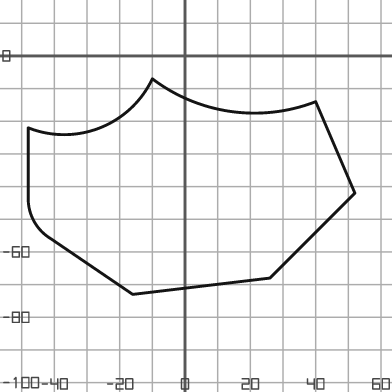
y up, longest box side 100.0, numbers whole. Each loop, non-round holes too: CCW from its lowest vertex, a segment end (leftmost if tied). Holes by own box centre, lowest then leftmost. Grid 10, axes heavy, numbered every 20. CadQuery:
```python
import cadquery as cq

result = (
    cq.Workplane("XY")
    .moveTo(-16.0, -73.0)
    .lineTo(26.0, -68.0)
    .lineTo(52.0, -42.0)
    .lineTo(40.0, -14.0)
    .threePointArc((14.0, -17.0), (-10.0, -7.0))
    .threePointArc((-26.0, -22.0), (-48.0, -22.0))
    .lineTo(-48.0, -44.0)
    .threePointArc((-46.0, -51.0), (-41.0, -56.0))
    .close()
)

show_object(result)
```